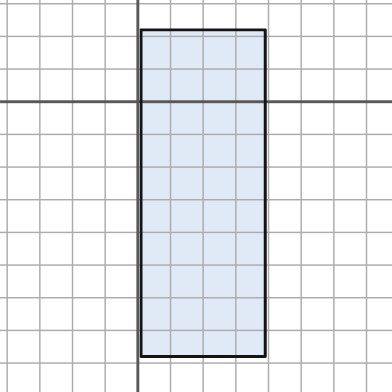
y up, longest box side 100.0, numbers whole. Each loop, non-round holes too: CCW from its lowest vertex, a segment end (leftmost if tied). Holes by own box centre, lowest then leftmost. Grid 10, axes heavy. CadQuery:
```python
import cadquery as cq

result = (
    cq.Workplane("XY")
    .moveTo(1.0, -78.0)
    .lineTo(39.0, -78.0)
    .lineTo(39.0, 22.0)
    .lineTo(1.0, 22.0)
    .close()
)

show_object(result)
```